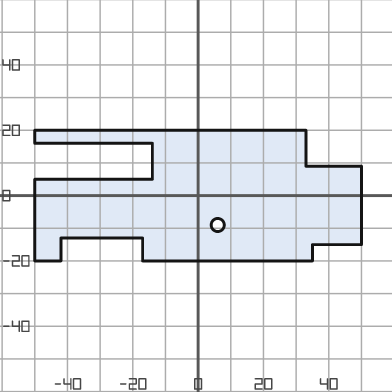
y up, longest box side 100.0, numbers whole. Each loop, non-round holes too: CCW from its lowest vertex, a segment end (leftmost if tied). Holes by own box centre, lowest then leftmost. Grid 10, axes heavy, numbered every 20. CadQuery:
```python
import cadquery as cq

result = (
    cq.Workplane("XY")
    .moveTo(-50.0, -20.0)
    .lineTo(-42.0, -20.0)
    .lineTo(-42.0, -13.0)
    .lineTo(-17.0, -13.0)
    .lineTo(-17.0, -20.0)
    .lineTo(35.0, -20.0)
    .lineTo(35.0, -15.0)
    .lineTo(50.0, -15.0)
    .lineTo(50.0, 9.0)
    .lineTo(33.0, 9.0)
    .lineTo(33.0, 20.0)
    .lineTo(-50.0, 20.0)
    .lineTo(-50.0, 16.0)
    .lineTo(-14.0, 16.0)
    .lineTo(-14.0, 5.0)
    .lineTo(-50.0, 5.0)
    .close()
    .moveTo(6.0, -9.0)
    .circle(2.0)
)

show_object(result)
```